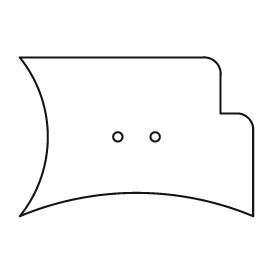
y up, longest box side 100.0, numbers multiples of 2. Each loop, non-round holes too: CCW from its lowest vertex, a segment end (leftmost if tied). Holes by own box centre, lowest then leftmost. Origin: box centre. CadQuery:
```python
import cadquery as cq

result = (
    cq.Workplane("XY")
    .moveTo(-50.0, -34.0)
    .threePointArc((0.0, -24.0), (50.0, -34.0))
    .lineTo(50.0, 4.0)
    .threePointArc((48.0, 8.0), (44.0, 10.0))
    .lineTo(36.0, 10.0)
    .lineTo(36.0, 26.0)
    .threePointArc((34.0, 32.0), (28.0, 34.0))
    .lineTo(-50.0, 34.0)
    .threePointArc((-38.0, 0.0), (-50.0, -34.0))
    .close()
    .moveTo(-8.0, 0.0)
    .circle(2.0)
    .moveTo(8.0, 0.0)
    .circle(2.0)
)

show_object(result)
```